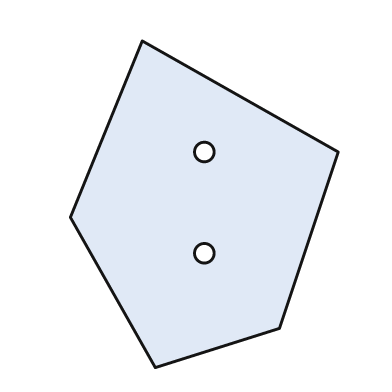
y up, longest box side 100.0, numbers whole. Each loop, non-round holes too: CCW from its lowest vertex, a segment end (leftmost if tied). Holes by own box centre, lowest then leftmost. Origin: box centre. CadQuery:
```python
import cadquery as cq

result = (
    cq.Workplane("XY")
    .moveTo(-15.0, -50.0)
    .lineTo(23.0, -38.0)
    .lineTo(41.0, 16.0)
    .lineTo(-19.0, 50.0)
    .lineTo(-41.0, -4.0)
    .close()
    .moveTo(0.0, -15.0)
    .circle(3.0)
    .moveTo(0.0, 16.0)
    .circle(3.0)
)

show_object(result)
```